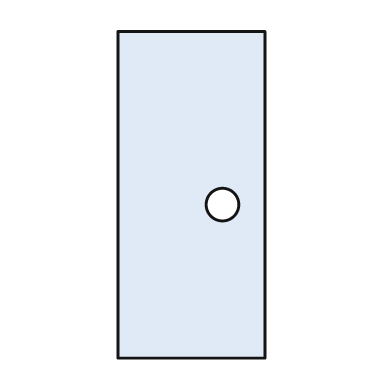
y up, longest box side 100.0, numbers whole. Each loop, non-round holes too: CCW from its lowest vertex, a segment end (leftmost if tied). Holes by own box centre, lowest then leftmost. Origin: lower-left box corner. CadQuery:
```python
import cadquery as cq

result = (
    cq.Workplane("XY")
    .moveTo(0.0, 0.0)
    .lineTo(45.0, 0.0)
    .lineTo(45.0, 100.0)
    .lineTo(0.0, 100.0)
    .close()
    .moveTo(32.0, 47.0)
    .circle(5.0)
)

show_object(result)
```